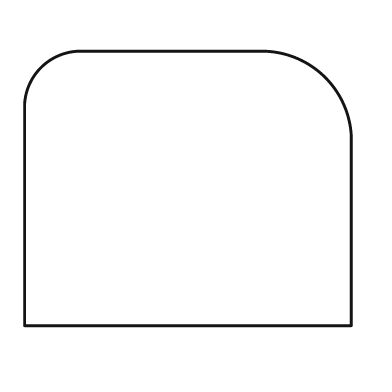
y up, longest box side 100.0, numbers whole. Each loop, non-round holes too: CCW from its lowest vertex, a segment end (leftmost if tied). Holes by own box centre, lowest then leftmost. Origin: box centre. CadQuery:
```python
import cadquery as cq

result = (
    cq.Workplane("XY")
    .moveTo(-50.0, -42.0)
    .lineTo(50.0, -42.0)
    .lineTo(50.0, 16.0)
    .threePointArc((42.0, 34.0), (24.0, 42.0))
    .lineTo(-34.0, 42.0)
    .threePointArc((-45.0, 37.0), (-50.0, 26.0))
    .close()
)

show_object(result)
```